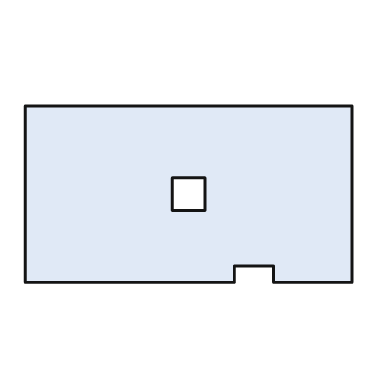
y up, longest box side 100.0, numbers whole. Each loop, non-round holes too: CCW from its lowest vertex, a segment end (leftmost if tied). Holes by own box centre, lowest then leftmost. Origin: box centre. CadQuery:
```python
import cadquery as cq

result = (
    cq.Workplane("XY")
    .moveTo(-50.0, -27.0)
    .lineTo(14.0, -27.0)
    .lineTo(14.0, -22.0)
    .lineTo(26.0, -22.0)
    .lineTo(26.0, -27.0)
    .lineTo(50.0, -27.0)
    .lineTo(50.0, 27.0)
    .lineTo(-50.0, 27.0)
    .close()
    .moveTo(-5.0, -5.0)
    .lineTo(5.0, -5.0)
    .lineTo(5.0, 5.0)
    .lineTo(-5.0, 5.0)
    .close()
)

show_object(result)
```